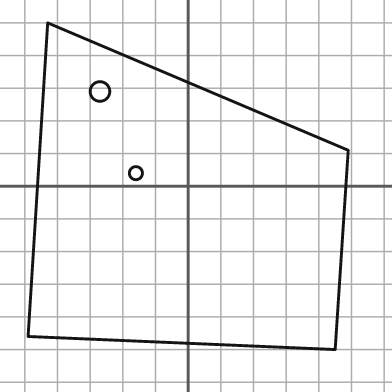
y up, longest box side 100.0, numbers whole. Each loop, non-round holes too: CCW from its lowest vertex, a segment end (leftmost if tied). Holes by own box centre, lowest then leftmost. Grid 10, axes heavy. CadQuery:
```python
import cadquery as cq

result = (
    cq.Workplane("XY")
    .moveTo(45.0, -50.0)
    .lineTo(49.0, 11.0)
    .lineTo(-43.0, 50.0)
    .lineTo(-49.0, -46.0)
    .close()
    .moveTo(-16.0, 4.0)
    .circle(2.0)
    .moveTo(-27.0, 29.0)
    .circle(3.0)
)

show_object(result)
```